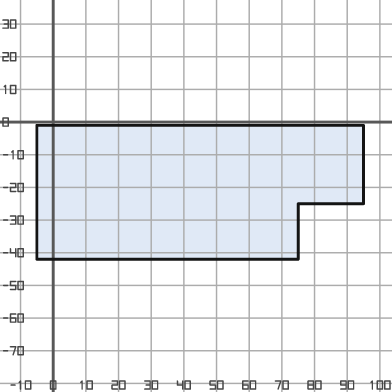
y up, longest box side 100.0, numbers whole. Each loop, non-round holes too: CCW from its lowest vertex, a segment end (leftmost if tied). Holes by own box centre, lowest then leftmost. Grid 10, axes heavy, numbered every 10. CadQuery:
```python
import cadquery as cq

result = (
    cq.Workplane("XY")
    .moveTo(-5.0, -42.0)
    .lineTo(75.0, -42.0)
    .lineTo(75.0, -25.0)
    .lineTo(95.0, -25.0)
    .lineTo(95.0, -1.0)
    .lineTo(-5.0, -1.0)
    .close()
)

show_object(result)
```